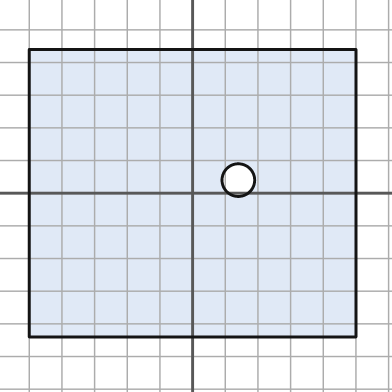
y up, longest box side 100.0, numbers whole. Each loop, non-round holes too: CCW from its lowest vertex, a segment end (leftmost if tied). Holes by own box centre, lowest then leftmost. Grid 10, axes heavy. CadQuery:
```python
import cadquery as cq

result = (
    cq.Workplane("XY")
    .moveTo(-50.0, -44.0)
    .lineTo(50.0, -44.0)
    .lineTo(50.0, 44.0)
    .lineTo(-50.0, 44.0)
    .close()
    .moveTo(14.0, 4.0)
    .circle(5.0)
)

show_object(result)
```